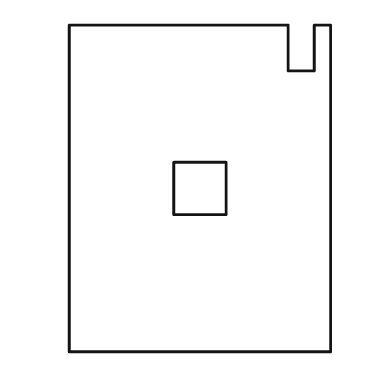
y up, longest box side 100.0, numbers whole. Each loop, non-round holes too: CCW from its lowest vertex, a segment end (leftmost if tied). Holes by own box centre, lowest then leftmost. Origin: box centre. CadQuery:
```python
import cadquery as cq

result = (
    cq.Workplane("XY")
    .moveTo(-40.0, -50.0)
    .lineTo(40.0, -50.0)
    .lineTo(40.0, 50.0)
    .lineTo(35.0, 50.0)
    .lineTo(35.0, 36.0)
    .lineTo(27.0, 36.0)
    .lineTo(27.0, 50.0)
    .lineTo(-40.0, 50.0)
    .close()
    .moveTo(-8.0, -8.0)
    .lineTo(8.0, -8.0)
    .lineTo(8.0, 8.0)
    .lineTo(-8.0, 8.0)
    .close()
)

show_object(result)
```